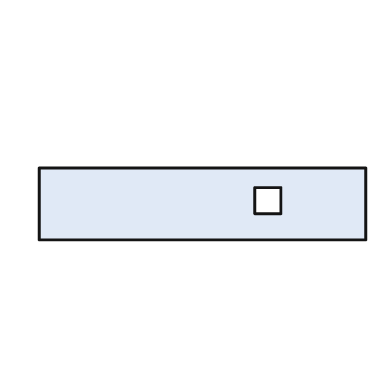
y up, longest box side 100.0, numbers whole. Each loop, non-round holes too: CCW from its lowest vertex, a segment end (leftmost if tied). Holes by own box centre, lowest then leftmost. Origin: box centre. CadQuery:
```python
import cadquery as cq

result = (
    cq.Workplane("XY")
    .moveTo(-50.0, -11.0)
    .lineTo(50.0, -11.0)
    .lineTo(50.0, 11.0)
    .lineTo(-50.0, 11.0)
    .close()
    .moveTo(16.0, -3.0)
    .lineTo(24.0, -3.0)
    .lineTo(24.0, 5.0)
    .lineTo(16.0, 5.0)
    .close()
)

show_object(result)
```